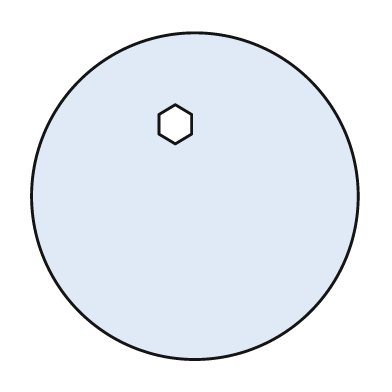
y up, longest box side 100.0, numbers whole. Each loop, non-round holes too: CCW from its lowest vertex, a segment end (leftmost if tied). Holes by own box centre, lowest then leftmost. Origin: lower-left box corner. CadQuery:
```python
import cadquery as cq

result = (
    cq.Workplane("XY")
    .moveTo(50.0, 50.0)
    .circle(50.0)
    .moveTo(44.0, 66.0)
    .lineTo(49.0, 69.0)
    .lineTo(49.0, 75.0)
    .lineTo(44.0, 78.0)
    .lineTo(39.0, 75.0)
    .lineTo(39.0, 69.0)
    .close()
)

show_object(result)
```